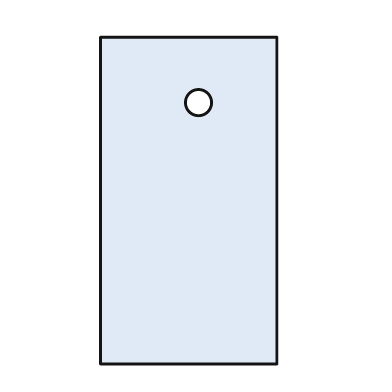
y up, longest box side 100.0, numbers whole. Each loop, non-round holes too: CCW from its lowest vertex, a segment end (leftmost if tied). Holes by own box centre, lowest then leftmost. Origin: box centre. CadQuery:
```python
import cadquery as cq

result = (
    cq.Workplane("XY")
    .moveTo(-27.0, -50.0)
    .lineTo(27.0, -50.0)
    .lineTo(27.0, 50.0)
    .lineTo(-27.0, 50.0)
    .close()
    .moveTo(3.0, 30.0)
    .circle(4.0)
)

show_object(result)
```